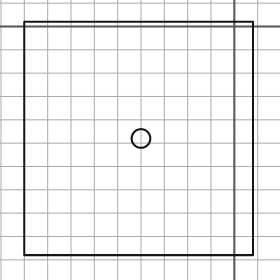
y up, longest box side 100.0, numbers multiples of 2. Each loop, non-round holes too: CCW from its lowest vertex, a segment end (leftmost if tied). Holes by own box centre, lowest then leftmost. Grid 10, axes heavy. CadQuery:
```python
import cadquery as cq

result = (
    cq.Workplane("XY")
    .moveTo(-90.0, -98.0)
    .lineTo(8.0, -98.0)
    .lineTo(8.0, 2.0)
    .lineTo(-90.0, 2.0)
    .close()
    .moveTo(-40.0, -48.0)
    .circle(4.0)
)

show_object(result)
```